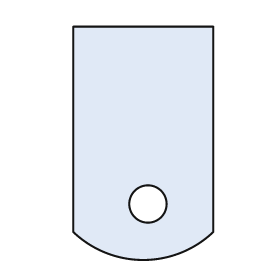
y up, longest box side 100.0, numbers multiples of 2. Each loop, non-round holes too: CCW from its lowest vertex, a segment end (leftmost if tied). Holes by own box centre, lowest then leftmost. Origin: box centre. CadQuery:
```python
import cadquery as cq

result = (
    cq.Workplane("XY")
    .moveTo(-30.0, -38.0)
    .threePointArc((0.0, -50.0), (30.0, -38.0))
    .lineTo(30.0, 50.0)
    .lineTo(-30.0, 50.0)
    .close()
    .moveTo(2.0, -26.0)
    .circle(8.0)
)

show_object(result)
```